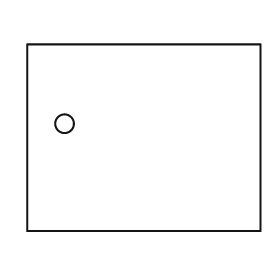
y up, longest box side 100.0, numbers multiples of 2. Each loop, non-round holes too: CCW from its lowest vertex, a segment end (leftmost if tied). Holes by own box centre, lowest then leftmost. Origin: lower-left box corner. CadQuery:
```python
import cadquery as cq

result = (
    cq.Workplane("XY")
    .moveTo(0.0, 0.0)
    .lineTo(100.0, 0.0)
    .lineTo(100.0, 80.0)
    .lineTo(0.0, 80.0)
    .close()
    .moveTo(16.0, 46.0)
    .circle(4.0)
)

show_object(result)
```